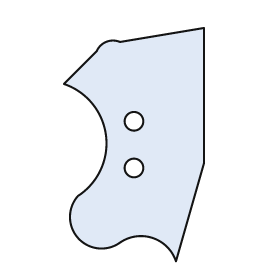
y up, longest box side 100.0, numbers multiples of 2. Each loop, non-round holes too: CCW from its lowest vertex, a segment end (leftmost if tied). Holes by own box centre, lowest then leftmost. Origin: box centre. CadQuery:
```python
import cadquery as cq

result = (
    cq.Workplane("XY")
    .moveTo(18.0, -50.0)
    .lineTo(30.0, -8.0)
    .lineTo(30.0, 50.0)
    .lineTo(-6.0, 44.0)
    .threePointArc((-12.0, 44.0), (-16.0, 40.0))
    .lineTo(-30.0, 26.0)
    .threePointArc((-12.0, 4.0), (-24.0, -22.0))
    .threePointArc((-24.0, -40.0), (-6.0, -42.0))
    .threePointArc((8.0, -40.0), (18.0, -50.0))
    .close()
    .moveTo(0.0, -10.0)
    .circle(4.0)
    .moveTo(0.0, 10.0)
    .circle(4.0)
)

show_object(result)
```